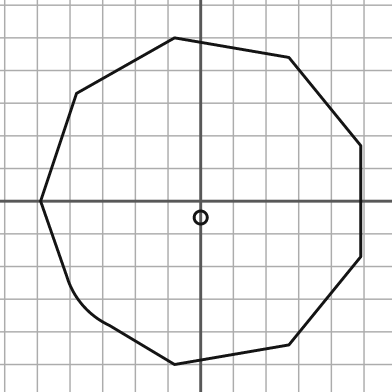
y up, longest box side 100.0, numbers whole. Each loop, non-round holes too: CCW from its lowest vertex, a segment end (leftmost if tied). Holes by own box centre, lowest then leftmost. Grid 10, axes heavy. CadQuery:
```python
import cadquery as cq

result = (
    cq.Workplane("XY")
    .moveTo(-8.0, -50.0)
    .lineTo(27.0, -44.0)
    .lineTo(49.0, -17.0)
    .lineTo(49.0, 17.0)
    .lineTo(27.0, 44.0)
    .lineTo(-8.0, 50.0)
    .lineTo(-38.0, 33.0)
    .lineTo(-49.0, 0.0)
    .lineTo(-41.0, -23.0)
    .threePointArc((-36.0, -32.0), (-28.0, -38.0))
    .close()
    .moveTo(0.0, -5.0)
    .circle(2.0)
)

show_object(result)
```